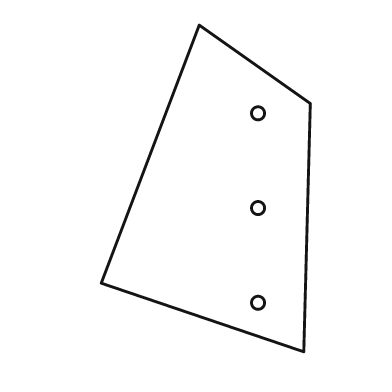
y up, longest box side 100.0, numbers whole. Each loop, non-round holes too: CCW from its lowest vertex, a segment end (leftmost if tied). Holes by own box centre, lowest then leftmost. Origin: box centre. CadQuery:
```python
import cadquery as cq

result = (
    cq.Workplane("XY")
    .moveTo(30.0, -50.0)
    .lineTo(32.0, 26.0)
    .lineTo(-2.0, 50.0)
    .lineTo(-32.0, -29.0)
    .close()
    .moveTo(16.0, -35.0)
    .circle(2.0)
    .moveTo(16.0, -6.0)
    .circle(2.0)
    .moveTo(16.0, 23.0)
    .circle(2.0)
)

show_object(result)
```